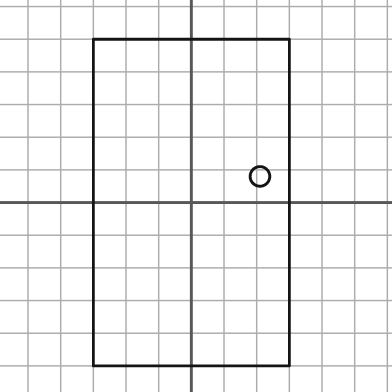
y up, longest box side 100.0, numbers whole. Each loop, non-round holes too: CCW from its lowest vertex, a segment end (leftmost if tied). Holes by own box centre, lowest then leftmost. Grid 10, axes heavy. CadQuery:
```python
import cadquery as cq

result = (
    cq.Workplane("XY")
    .moveTo(-30.0, -50.0)
    .lineTo(30.0, -50.0)
    .lineTo(30.0, 50.0)
    .lineTo(-30.0, 50.0)
    .close()
    .moveTo(21.0, 8.0)
    .circle(3.0)
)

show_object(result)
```